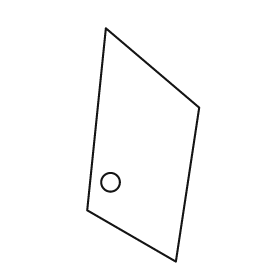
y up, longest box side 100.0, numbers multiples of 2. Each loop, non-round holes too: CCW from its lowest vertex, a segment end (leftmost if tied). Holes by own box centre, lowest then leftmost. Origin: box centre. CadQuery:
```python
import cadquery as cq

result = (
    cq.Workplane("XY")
    .moveTo(14.0, -50.0)
    .lineTo(24.0, 16.0)
    .lineTo(-16.0, 50.0)
    .lineTo(-24.0, -28.0)
    .close()
    .moveTo(-14.0, -16.0)
    .circle(4.0)
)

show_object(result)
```